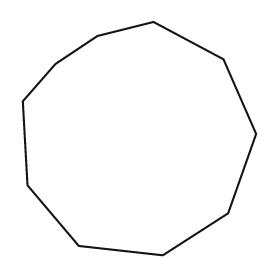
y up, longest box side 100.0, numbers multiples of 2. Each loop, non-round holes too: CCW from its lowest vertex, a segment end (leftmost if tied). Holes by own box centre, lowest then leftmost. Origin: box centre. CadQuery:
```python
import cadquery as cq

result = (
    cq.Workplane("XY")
    .moveTo(10.0, -50.0)
    .lineTo(38.0, -32.0)
    .lineTo(50.0, 2.0)
    .lineTo(36.0, 34.0)
    .lineTo(6.0, 50.0)
    .lineTo(-18.0, 44.0)
    .lineTo(-36.0, 32.0)
    .lineTo(-50.0, 16.0)
    .lineTo(-48.0, -20.0)
    .lineTo(-26.0, -46.0)
    .close()
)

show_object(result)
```